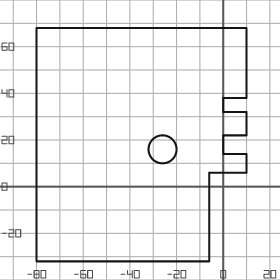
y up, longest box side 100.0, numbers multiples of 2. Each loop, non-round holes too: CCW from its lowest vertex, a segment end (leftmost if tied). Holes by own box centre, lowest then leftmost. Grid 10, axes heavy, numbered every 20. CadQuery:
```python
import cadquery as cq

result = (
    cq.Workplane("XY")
    .moveTo(-80.0, -32.0)
    .lineTo(-6.0, -32.0)
    .lineTo(-6.0, 6.0)
    .lineTo(10.0, 6.0)
    .lineTo(10.0, 14.0)
    .lineTo(0.0, 14.0)
    .lineTo(0.0, 22.0)
    .lineTo(10.0, 22.0)
    .lineTo(10.0, 32.0)
    .lineTo(0.0, 32.0)
    .lineTo(0.0, 38.0)
    .lineTo(10.0, 38.0)
    .lineTo(10.0, 68.0)
    .lineTo(-80.0, 68.0)
    .close()
    .moveTo(-26.0, 16.0)
    .circle(6.0)
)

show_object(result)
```